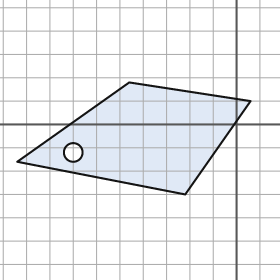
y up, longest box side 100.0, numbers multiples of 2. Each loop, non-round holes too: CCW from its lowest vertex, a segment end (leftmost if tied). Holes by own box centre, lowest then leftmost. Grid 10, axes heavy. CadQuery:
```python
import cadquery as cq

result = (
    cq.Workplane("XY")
    .moveTo(-22.0, -30.0)
    .lineTo(6.0, 10.0)
    .lineTo(-46.0, 18.0)
    .lineTo(-94.0, -16.0)
    .close()
    .moveTo(-70.0, -12.0)
    .circle(4.0)
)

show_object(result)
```